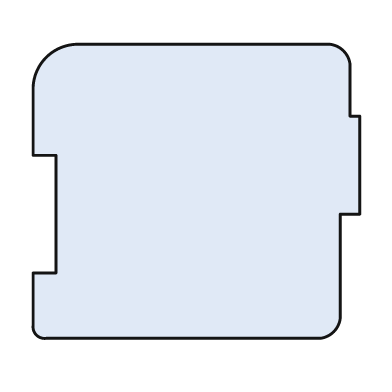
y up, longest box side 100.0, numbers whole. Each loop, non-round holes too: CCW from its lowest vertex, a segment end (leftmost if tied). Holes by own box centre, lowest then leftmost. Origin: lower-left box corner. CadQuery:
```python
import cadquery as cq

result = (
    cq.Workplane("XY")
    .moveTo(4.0, 0.0)
    .lineTo(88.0, 0.0)
    .threePointArc((92.0, 2.0), (94.0, 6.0))
    .lineTo(94.0, 38.0)
    .lineTo(100.0, 38.0)
    .lineTo(100.0, 68.0)
    .lineTo(97.0, 68.0)
    .lineTo(97.0, 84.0)
    .threePointArc((95.0, 88.0), (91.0, 90.0))
    .lineTo(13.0, 90.0)
    .threePointArc((4.0, 86.0), (0.0, 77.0))
    .lineTo(0.0, 56.0)
    .lineTo(7.0, 56.0)
    .lineTo(7.0, 20.0)
    .lineTo(0.0, 20.0)
    .lineTo(0.0, 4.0)
    .threePointArc((1.0, 1.0), (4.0, 0.0))
    .close()
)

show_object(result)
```